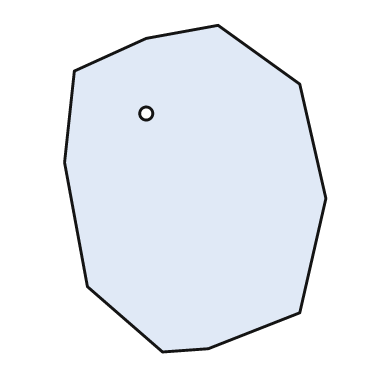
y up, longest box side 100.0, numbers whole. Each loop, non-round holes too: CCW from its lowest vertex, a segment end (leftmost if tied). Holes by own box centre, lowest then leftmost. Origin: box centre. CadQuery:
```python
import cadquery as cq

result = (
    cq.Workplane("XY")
    .moveTo(-10.0, -50.0)
    .lineTo(4.0, -49.0)
    .lineTo(32.0, -38.0)
    .lineTo(40.0, -3.0)
    .lineTo(32.0, 32.0)
    .lineTo(7.0, 50.0)
    .lineTo(-15.0, 46.0)
    .lineTo(-37.0, 36.0)
    .lineTo(-40.0, 8.0)
    .lineTo(-33.0, -30.0)
    .close()
    .moveTo(-15.0, 23.0)
    .circle(2.0)
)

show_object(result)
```